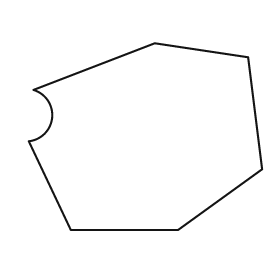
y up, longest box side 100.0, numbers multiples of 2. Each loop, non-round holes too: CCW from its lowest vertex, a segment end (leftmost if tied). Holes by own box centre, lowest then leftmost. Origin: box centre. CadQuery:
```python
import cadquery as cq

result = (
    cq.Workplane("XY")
    .moveTo(-32.0, -40.0)
    .lineTo(14.0, -40.0)
    .lineTo(50.0, -14.0)
    .lineTo(44.0, 34.0)
    .lineTo(4.0, 40.0)
    .lineTo(-48.0, 20.0)
    .threePointArc((-40.0, 8.0), (-50.0, -2.0))
    .close()
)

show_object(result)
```